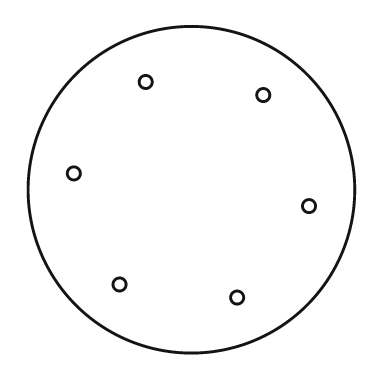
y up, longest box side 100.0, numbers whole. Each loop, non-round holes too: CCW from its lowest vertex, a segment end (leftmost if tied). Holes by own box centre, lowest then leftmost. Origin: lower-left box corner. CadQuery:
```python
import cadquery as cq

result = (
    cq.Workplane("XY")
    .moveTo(50.0, 50.0)
    .circle(50.0)
    .moveTo(64.0, 17.0)
    .circle(2.0)
    .moveTo(28.0, 21.0)
    .circle(2.0)
    .moveTo(86.0, 45.0)
    .circle(2.0)
    .moveTo(14.0, 55.0)
    .circle(2.0)
    .moveTo(72.0, 79.0)
    .circle(2.0)
    .moveTo(36.0, 83.0)
    .circle(2.0)
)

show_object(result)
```